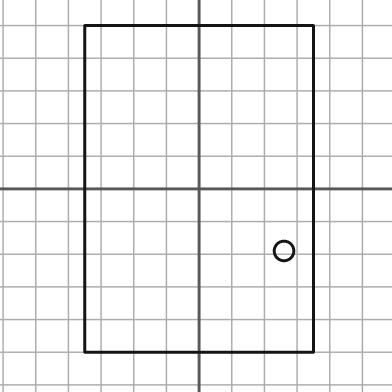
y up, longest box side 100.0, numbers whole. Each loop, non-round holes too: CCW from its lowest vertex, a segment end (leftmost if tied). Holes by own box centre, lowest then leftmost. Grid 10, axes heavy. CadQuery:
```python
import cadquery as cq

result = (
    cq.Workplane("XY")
    .moveTo(-35.0, -50.0)
    .lineTo(35.0, -50.0)
    .lineTo(35.0, 50.0)
    .lineTo(-35.0, 50.0)
    .close()
    .moveTo(26.0, -19.0)
    .circle(3.0)
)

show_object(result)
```